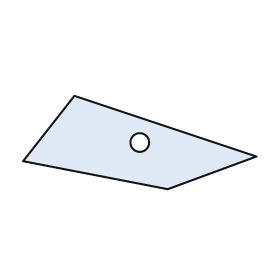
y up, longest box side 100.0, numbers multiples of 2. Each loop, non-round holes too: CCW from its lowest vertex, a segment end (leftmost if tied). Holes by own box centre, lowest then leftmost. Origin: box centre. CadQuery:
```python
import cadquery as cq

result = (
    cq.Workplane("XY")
    .moveTo(12.0, -20.0)
    .lineTo(50.0, -6.0)
    .lineTo(-28.0, 20.0)
    .lineTo(-50.0, -8.0)
    .close()
    .moveTo(0.0, 0.0)
    .circle(4.0)
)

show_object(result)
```